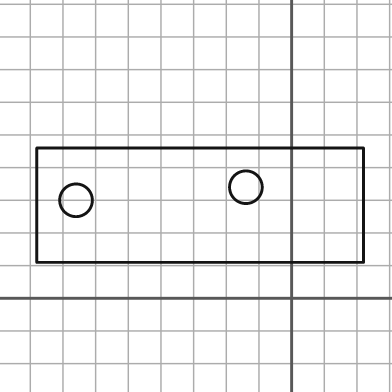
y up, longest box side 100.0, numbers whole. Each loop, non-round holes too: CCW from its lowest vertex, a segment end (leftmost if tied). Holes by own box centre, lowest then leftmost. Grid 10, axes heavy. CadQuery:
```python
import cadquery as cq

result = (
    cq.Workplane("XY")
    .moveTo(-78.0, 11.0)
    .lineTo(22.0, 11.0)
    .lineTo(22.0, 46.0)
    .lineTo(-78.0, 46.0)
    .close()
    .moveTo(-66.0, 30.0)
    .circle(5.0)
    .moveTo(-14.0, 34.0)
    .circle(5.0)
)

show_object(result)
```